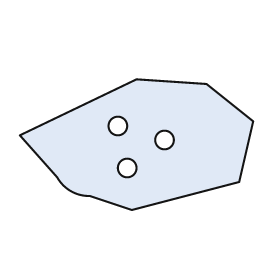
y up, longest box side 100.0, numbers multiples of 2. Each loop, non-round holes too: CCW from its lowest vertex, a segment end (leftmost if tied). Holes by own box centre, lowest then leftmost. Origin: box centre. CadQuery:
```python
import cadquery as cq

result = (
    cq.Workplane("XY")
    .moveTo(-2.0, -28.0)
    .lineTo(44.0, -16.0)
    .lineTo(50.0, 10.0)
    .lineTo(30.0, 26.0)
    .lineTo(0.0, 28.0)
    .lineTo(-50.0, 4.0)
    .lineTo(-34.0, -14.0)
    .threePointArc((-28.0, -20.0), (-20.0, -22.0))
    .close()
    .moveTo(-4.0, -10.0)
    .circle(4.0)
    .moveTo(12.0, 2.0)
    .circle(4.0)
    .moveTo(-8.0, 8.0)
    .circle(4.0)
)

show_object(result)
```